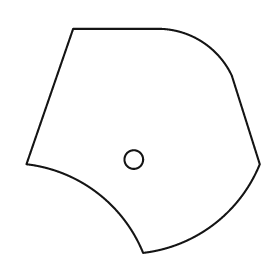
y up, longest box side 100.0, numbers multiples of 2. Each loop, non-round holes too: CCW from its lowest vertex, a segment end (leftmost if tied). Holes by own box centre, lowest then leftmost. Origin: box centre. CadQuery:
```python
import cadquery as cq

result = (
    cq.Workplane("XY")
    .moveTo(0.0, -48.0)
    .threePointArc((30.0, -36.0), (50.0, -10.0))
    .lineTo(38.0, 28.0)
    .threePointArc((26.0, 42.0), (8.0, 48.0))
    .lineTo(-30.0, 48.0)
    .lineTo(-50.0, -10.0)
    .threePointArc((-20.0, -22.0), (0.0, -48.0))
    .close()
    .moveTo(-4.0, -8.0)
    .circle(4.0)
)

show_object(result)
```